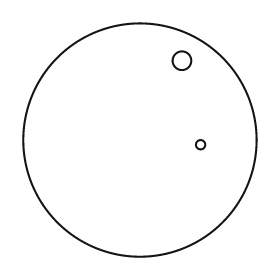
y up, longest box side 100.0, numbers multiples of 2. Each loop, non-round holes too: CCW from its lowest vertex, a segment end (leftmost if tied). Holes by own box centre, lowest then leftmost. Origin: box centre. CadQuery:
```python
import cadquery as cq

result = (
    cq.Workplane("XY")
    .moveTo(0.0, 0.0)
    .circle(50.0)
    .moveTo(26.0, -2.0)
    .circle(2.0)
    .moveTo(18.0, 34.0)
    .circle(4.0)
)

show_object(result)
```